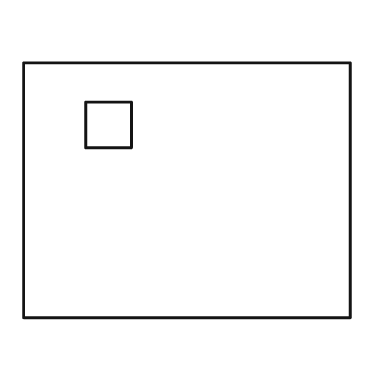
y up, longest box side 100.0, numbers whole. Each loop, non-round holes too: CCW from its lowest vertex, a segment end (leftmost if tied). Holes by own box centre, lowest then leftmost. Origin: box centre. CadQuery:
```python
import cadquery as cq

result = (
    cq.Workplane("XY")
    .moveTo(-50.0, -39.0)
    .lineTo(50.0, -39.0)
    .lineTo(50.0, 39.0)
    .lineTo(-50.0, 39.0)
    .close()
    .moveTo(-31.0, 13.0)
    .lineTo(-17.0, 13.0)
    .lineTo(-17.0, 27.0)
    .lineTo(-31.0, 27.0)
    .close()
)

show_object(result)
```